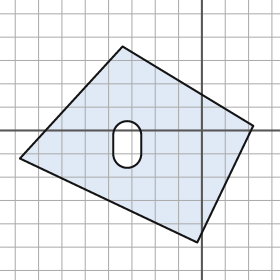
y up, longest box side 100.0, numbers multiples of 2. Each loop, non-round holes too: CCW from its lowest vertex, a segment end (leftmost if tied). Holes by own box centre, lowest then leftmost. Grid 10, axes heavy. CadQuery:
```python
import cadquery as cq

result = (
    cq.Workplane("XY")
    .moveTo(-2.0, -48.0)
    .lineTo(22.0, 2.0)
    .lineTo(-34.0, 36.0)
    .lineTo(-78.0, -12.0)
    .close()
    .moveTo(-38.0, -10.0)
    .threePointArc((-32.0, -16.0), (-26.0, -10.0))
    .lineTo(-26.0, -2.0)
    .threePointArc((-32.0, 4.0), (-38.0, -2.0))
    .close()
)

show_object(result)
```